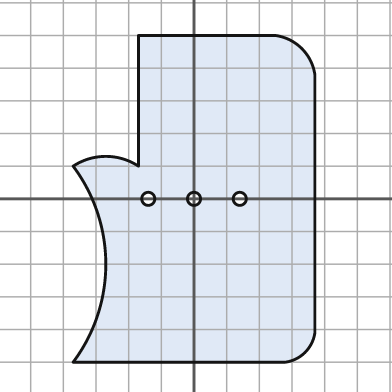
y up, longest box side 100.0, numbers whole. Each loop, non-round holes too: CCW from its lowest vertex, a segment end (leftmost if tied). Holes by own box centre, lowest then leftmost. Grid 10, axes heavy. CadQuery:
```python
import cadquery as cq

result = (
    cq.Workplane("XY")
    .moveTo(-37.0, -50.0)
    .lineTo(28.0, -50.0)
    .threePointArc((34.0, -47.0), (37.0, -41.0))
    .lineTo(37.0, 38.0)
    .threePointArc((33.0, 46.0), (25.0, 50.0))
    .lineTo(-17.0, 50.0)
    .lineTo(-17.0, 10.0)
    .threePointArc((-27.0, 13.0), (-37.0, 10.0))
    .threePointArc((-27.0, -20.0), (-37.0, -50.0))
    .close()
    .moveTo(-14.0, 0.0)
    .circle(2.0)
    .moveTo(0.0, 0.0)
    .circle(2.0)
    .moveTo(14.0, 0.0)
    .circle(2.0)
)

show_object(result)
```